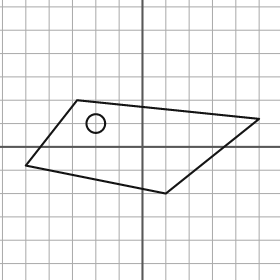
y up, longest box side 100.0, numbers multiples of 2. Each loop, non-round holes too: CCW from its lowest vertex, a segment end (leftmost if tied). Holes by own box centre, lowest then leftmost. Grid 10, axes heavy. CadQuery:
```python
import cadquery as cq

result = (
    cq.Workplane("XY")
    .moveTo(10.0, -20.0)
    .lineTo(50.0, 12.0)
    .lineTo(-28.0, 20.0)
    .lineTo(-50.0, -8.0)
    .close()
    .moveTo(-20.0, 10.0)
    .circle(4.0)
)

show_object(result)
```